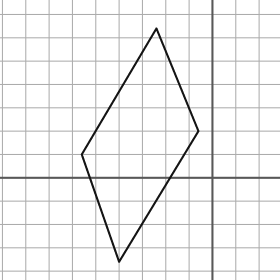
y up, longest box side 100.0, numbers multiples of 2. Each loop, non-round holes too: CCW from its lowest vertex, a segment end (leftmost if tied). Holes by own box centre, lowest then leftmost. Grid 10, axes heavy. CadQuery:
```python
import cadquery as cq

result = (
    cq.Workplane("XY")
    .moveTo(-40.0, -36.0)
    .lineTo(-6.0, 20.0)
    .lineTo(-24.0, 64.0)
    .lineTo(-56.0, 10.0)
    .close()
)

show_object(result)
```